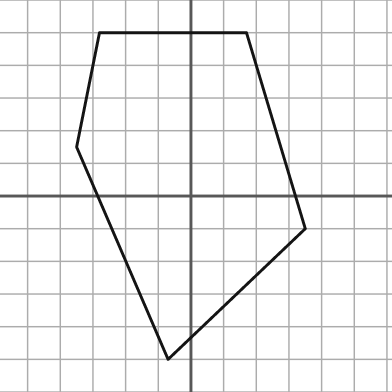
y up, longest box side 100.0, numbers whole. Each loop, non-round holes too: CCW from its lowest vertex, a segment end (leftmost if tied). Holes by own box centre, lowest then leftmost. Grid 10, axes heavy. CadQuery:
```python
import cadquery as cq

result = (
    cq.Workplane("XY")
    .moveTo(-7.0, -50.0)
    .lineTo(35.0, -10.0)
    .lineTo(17.0, 50.0)
    .lineTo(-28.0, 50.0)
    .lineTo(-35.0, 15.0)
    .close()
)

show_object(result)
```